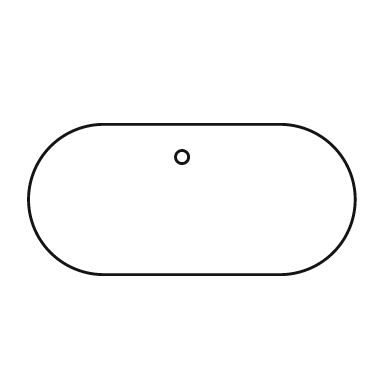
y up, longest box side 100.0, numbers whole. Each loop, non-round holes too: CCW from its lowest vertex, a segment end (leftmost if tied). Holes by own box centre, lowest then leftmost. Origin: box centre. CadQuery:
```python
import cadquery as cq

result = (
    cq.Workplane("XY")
    .moveTo(-27.0, -23.0)
    .lineTo(27.0, -23.0)
    .threePointArc((50.0, 0.0), (27.0, 23.0))
    .lineTo(-27.0, 23.0)
    .threePointArc((-50.0, 0.0), (-27.0, -23.0))
    .close()
    .moveTo(-3.0, 13.0)
    .circle(2.0)
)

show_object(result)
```